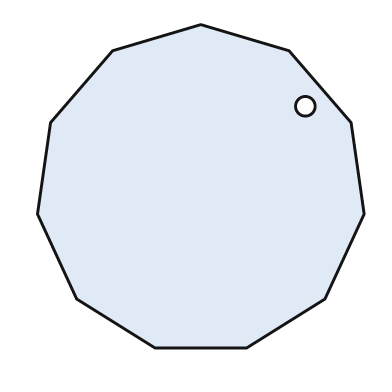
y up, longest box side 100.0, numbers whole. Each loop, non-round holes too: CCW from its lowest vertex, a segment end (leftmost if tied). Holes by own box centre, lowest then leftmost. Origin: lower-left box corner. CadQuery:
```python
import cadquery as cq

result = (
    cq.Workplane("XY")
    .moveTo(36.0, 0.0)
    .lineTo(64.0, 0.0)
    .lineTo(88.0, 15.0)
    .lineTo(100.0, 41.0)
    .lineTo(96.0, 69.0)
    .lineTo(77.0, 91.0)
    .lineTo(50.0, 99.0)
    .lineTo(23.0, 91.0)
    .lineTo(4.0, 69.0)
    .lineTo(0.0, 41.0)
    .lineTo(12.0, 15.0)
    .close()
    .moveTo(82.0, 74.0)
    .circle(3.0)
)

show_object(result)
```